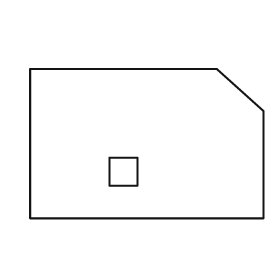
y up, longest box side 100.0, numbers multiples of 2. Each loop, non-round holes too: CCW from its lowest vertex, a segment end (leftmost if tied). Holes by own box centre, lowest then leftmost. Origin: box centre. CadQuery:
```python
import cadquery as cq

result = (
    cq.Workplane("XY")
    .moveTo(-50.0, -32.0)
    .lineTo(50.0, -32.0)
    .lineTo(50.0, 14.0)
    .lineTo(30.0, 32.0)
    .lineTo(-50.0, 32.0)
    .close()
    .moveTo(-16.0, -18.0)
    .lineTo(-4.0, -18.0)
    .lineTo(-4.0, -6.0)
    .lineTo(-16.0, -6.0)
    .close()
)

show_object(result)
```